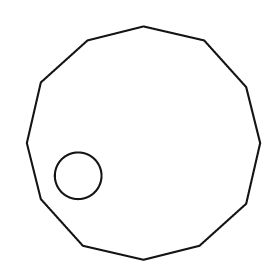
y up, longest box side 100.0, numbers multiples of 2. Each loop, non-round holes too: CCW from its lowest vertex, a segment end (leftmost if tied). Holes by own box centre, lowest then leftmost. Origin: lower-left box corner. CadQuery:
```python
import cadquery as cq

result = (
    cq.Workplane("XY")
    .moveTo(50.0, 0.0)
    .lineTo(74.0, 6.0)
    .lineTo(94.0, 24.0)
    .lineTo(100.0, 50.0)
    .lineTo(94.0, 74.0)
    .lineTo(76.0, 94.0)
    .lineTo(50.0, 100.0)
    .lineTo(26.0, 94.0)
    .lineTo(6.0, 76.0)
    .lineTo(0.0, 50.0)
    .lineTo(6.0, 26.0)
    .lineTo(24.0, 6.0)
    .close()
    .moveTo(22.0, 36.0)
    .circle(10.0)
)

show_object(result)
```